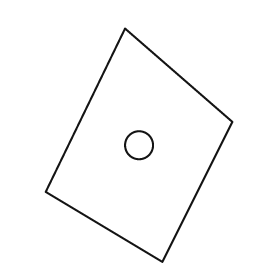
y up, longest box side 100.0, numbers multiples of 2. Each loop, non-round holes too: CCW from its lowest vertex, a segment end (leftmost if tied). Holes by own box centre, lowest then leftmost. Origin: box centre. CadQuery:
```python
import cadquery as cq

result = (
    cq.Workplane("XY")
    .moveTo(10.0, -50.0)
    .lineTo(40.0, 10.0)
    .lineTo(-6.0, 50.0)
    .lineTo(-40.0, -20.0)
    .close()
    .moveTo(0.0, 0.0)
    .circle(6.0)
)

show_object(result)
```